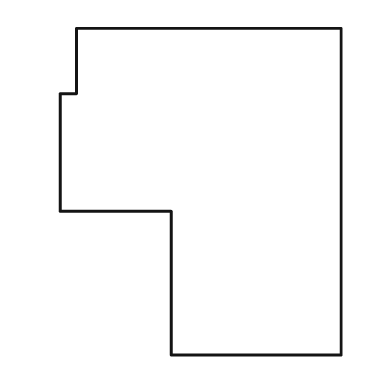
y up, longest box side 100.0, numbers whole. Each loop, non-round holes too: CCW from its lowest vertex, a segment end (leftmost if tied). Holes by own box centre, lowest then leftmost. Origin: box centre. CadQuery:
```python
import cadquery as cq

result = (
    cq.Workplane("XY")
    .moveTo(-9.0, -50.0)
    .lineTo(43.0, -50.0)
    .lineTo(43.0, 50.0)
    .lineTo(-38.0, 50.0)
    .lineTo(-38.0, 30.0)
    .lineTo(-43.0, 30.0)
    .lineTo(-43.0, -6.0)
    .lineTo(-9.0, -6.0)
    .close()
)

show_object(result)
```